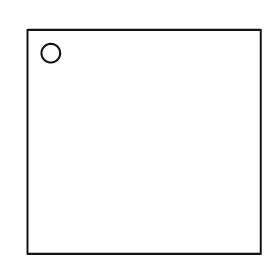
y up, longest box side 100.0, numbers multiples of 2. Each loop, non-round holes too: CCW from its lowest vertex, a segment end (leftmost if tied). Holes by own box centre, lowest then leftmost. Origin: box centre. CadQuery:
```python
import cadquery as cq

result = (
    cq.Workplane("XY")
    .moveTo(-50.0, -48.0)
    .lineTo(50.0, -48.0)
    .lineTo(50.0, 48.0)
    .lineTo(-50.0, 48.0)
    .close()
    .moveTo(-40.0, 38.0)
    .circle(4.0)
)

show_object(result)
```